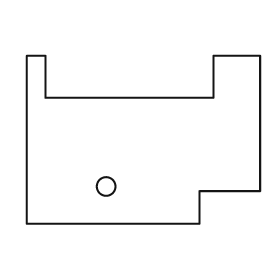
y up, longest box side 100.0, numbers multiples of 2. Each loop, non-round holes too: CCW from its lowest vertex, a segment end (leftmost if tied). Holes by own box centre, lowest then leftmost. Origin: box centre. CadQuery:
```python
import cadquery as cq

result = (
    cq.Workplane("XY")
    .moveTo(-50.0, -36.0)
    .lineTo(24.0, -36.0)
    .lineTo(24.0, -22.0)
    .lineTo(50.0, -22.0)
    .lineTo(50.0, 36.0)
    .lineTo(30.0, 36.0)
    .lineTo(30.0, 18.0)
    .lineTo(-42.0, 18.0)
    .lineTo(-42.0, 36.0)
    .lineTo(-50.0, 36.0)
    .close()
    .moveTo(-16.0, -20.0)
    .circle(4.0)
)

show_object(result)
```